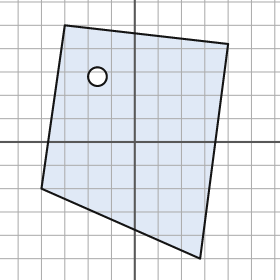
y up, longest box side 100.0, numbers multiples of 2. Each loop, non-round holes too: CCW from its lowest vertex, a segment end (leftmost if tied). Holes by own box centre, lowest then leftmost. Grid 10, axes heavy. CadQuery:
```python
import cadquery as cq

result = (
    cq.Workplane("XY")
    .moveTo(28.0, -50.0)
    .lineTo(40.0, 42.0)
    .lineTo(-30.0, 50.0)
    .lineTo(-40.0, -20.0)
    .close()
    .moveTo(-16.0, 28.0)
    .circle(4.0)
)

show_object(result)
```